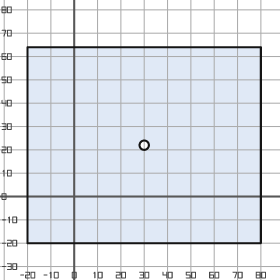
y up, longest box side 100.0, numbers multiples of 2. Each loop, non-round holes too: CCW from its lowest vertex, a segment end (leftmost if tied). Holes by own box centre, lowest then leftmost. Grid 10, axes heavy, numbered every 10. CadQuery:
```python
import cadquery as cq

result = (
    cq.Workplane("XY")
    .moveTo(-20.0, -20.0)
    .lineTo(80.0, -20.0)
    .lineTo(80.0, 64.0)
    .lineTo(-20.0, 64.0)
    .close()
    .moveTo(30.0, 22.0)
    .circle(2.0)
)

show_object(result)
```